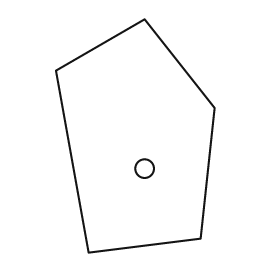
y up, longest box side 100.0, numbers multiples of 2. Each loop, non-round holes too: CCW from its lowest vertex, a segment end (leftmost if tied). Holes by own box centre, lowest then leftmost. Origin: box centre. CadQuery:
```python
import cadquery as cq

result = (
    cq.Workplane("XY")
    .moveTo(-20.0, -50.0)
    .lineTo(28.0, -44.0)
    .lineTo(34.0, 12.0)
    .lineTo(4.0, 50.0)
    .lineTo(-34.0, 28.0)
    .close()
    .moveTo(4.0, -14.0)
    .circle(4.0)
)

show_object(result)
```